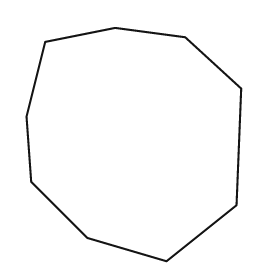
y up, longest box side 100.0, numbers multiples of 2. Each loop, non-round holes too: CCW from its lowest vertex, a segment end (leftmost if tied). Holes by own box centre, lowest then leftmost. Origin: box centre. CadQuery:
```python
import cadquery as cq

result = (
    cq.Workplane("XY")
    .moveTo(14.0, -50.0)
    .lineTo(44.0, -26.0)
    .lineTo(46.0, 24.0)
    .lineTo(22.0, 46.0)
    .lineTo(-8.0, 50.0)
    .lineTo(-38.0, 44.0)
    .lineTo(-46.0, 12.0)
    .lineTo(-44.0, -16.0)
    .lineTo(-20.0, -40.0)
    .close()
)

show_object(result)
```